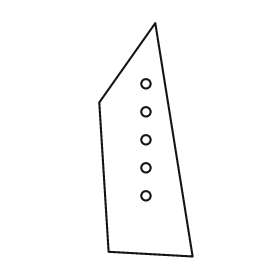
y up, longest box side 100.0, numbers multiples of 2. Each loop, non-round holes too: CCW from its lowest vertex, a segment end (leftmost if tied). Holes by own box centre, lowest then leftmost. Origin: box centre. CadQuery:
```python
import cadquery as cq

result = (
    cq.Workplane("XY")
    .moveTo(20.0, -50.0)
    .lineTo(4.0, 50.0)
    .lineTo(-20.0, 16.0)
    .lineTo(-16.0, -48.0)
    .close()
    .moveTo(0.0, -24.0)
    .circle(2.0)
    .moveTo(0.0, -12.0)
    .circle(2.0)
    .moveTo(0.0, 0.0)
    .circle(2.0)
    .moveTo(0.0, 12.0)
    .circle(2.0)
    .moveTo(0.0, 24.0)
    .circle(2.0)
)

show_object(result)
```